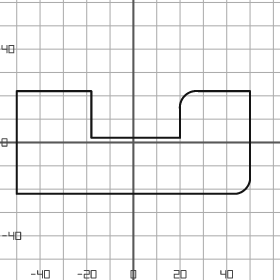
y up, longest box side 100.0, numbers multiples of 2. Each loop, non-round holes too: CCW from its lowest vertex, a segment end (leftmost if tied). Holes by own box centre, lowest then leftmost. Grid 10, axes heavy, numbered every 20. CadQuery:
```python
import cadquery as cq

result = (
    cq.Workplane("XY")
    .moveTo(-50.0, -22.0)
    .lineTo(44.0, -22.0)
    .threePointArc((48.0, -20.0), (50.0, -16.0))
    .lineTo(50.0, 22.0)
    .lineTo(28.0, 22.0)
    .threePointArc((22.0, 20.0), (20.0, 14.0))
    .lineTo(20.0, 2.0)
    .lineTo(-18.0, 2.0)
    .lineTo(-18.0, 22.0)
    .lineTo(-50.0, 22.0)
    .close()
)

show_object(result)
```